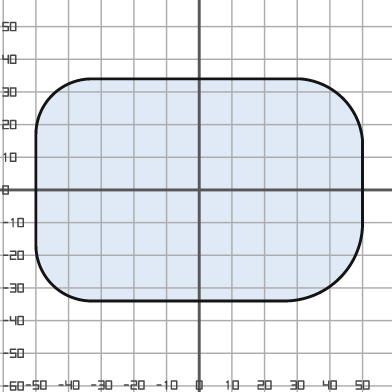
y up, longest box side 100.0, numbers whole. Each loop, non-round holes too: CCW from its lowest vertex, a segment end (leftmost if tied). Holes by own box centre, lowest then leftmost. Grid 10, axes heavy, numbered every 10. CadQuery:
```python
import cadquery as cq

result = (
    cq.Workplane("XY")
    .moveTo(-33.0, -34.0)
    .lineTo(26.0, -34.0)
    .threePointArc((43.0, -27.0), (50.0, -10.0))
    .lineTo(50.0, 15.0)
    .threePointArc((44.0, 28.0), (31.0, 34.0))
    .lineTo(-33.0, 34.0)
    .threePointArc((-45.0, 29.0), (-50.0, 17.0))
    .lineTo(-50.0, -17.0)
    .threePointArc((-45.0, -29.0), (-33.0, -34.0))
    .close()
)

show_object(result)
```